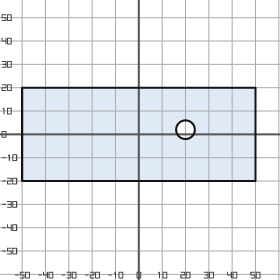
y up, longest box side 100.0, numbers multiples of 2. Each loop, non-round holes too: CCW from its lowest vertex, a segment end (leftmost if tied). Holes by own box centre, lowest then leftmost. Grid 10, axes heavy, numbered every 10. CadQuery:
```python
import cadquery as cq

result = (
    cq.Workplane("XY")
    .moveTo(-50.0, -20.0)
    .lineTo(50.0, -20.0)
    .lineTo(50.0, 20.0)
    .lineTo(-50.0, 20.0)
    .close()
    .moveTo(20.0, 2.0)
    .circle(4.0)
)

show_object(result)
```